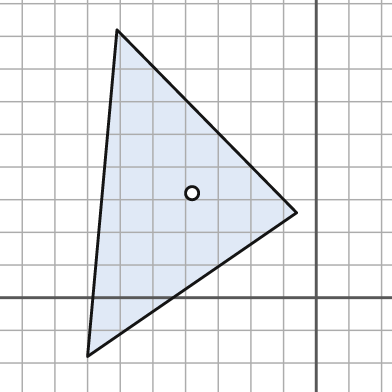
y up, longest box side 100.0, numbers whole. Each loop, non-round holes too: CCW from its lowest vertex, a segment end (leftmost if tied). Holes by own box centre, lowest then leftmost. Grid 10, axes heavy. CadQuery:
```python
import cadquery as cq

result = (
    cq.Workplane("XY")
    .moveTo(-70.0, -18.0)
    .lineTo(-6.0, 26.0)
    .lineTo(-61.0, 82.0)
    .close()
    .moveTo(-38.0, 32.0)
    .circle(2.0)
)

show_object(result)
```